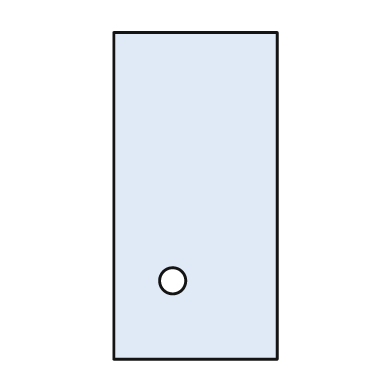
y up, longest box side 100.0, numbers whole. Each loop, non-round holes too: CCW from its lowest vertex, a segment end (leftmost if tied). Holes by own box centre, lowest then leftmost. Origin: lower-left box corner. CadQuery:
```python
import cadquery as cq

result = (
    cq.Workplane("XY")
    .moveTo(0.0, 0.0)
    .lineTo(50.0, 0.0)
    .lineTo(50.0, 100.0)
    .lineTo(0.0, 100.0)
    .close()
    .moveTo(18.0, 24.0)
    .circle(4.0)
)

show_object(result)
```